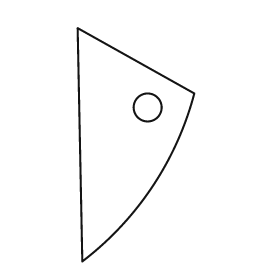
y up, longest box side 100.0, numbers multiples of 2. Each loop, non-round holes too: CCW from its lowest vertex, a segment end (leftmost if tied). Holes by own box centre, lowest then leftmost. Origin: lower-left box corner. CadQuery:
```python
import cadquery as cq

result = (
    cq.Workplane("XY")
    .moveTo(2.0, 0.0)
    .threePointArc((32.0, 32.0), (50.0, 72.0))
    .lineTo(0.0, 100.0)
    .close()
    .moveTo(30.0, 66.0)
    .circle(6.0)
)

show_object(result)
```